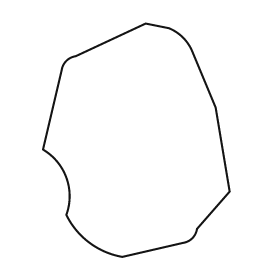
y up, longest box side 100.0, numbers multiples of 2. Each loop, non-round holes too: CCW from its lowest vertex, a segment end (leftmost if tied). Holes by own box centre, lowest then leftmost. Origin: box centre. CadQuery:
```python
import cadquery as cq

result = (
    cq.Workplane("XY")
    .moveTo(-6.0, -50.0)
    .lineTo(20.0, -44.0)
    .threePointArc((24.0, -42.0), (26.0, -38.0))
    .lineTo(40.0, -22.0)
    .lineTo(34.0, 14.0)
    .lineTo(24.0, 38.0)
    .threePointArc((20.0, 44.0), (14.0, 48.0))
    .lineTo(4.0, 50.0)
    .lineTo(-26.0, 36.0)
    .threePointArc((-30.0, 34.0), (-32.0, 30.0))
    .lineTo(-40.0, -4.0)
    .threePointArc((-30.0, -16.0), (-30.0, -32.0))
    .threePointArc((-20.0, -44.0), (-6.0, -50.0))
    .close()
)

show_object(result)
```